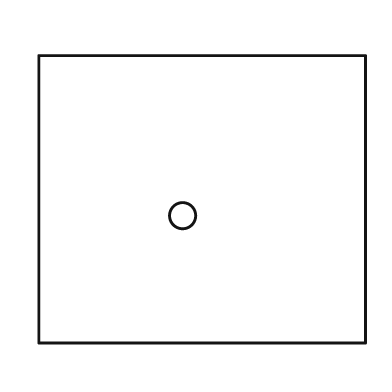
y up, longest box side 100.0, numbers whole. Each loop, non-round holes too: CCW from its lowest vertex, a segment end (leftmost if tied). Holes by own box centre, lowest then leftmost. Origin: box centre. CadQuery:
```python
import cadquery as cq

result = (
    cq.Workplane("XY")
    .moveTo(-50.0, -44.0)
    .lineTo(50.0, -44.0)
    .lineTo(50.0, 44.0)
    .lineTo(-50.0, 44.0)
    .close()
    .moveTo(-6.0, -5.0)
    .circle(4.0)
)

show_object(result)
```